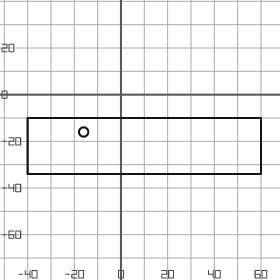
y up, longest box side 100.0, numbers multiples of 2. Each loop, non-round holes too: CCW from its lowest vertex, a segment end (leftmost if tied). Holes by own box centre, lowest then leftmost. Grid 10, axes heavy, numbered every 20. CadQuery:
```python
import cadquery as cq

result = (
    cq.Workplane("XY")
    .moveTo(-40.0, -34.0)
    .lineTo(60.0, -34.0)
    .lineTo(60.0, -10.0)
    .lineTo(-40.0, -10.0)
    .close()
    .moveTo(-16.0, -16.0)
    .circle(2.0)
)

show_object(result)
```